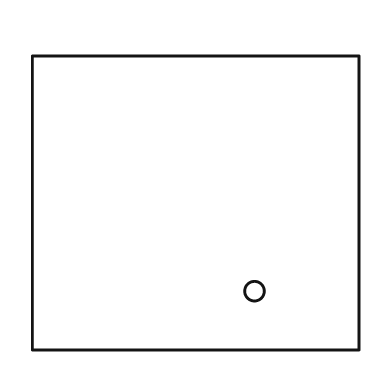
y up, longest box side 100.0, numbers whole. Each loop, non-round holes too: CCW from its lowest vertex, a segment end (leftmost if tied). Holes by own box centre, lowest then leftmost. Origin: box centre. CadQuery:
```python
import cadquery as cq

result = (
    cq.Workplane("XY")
    .moveTo(-50.0, -45.0)
    .lineTo(50.0, -45.0)
    .lineTo(50.0, 45.0)
    .lineTo(-50.0, 45.0)
    .close()
    .moveTo(18.0, -27.0)
    .circle(3.0)
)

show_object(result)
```